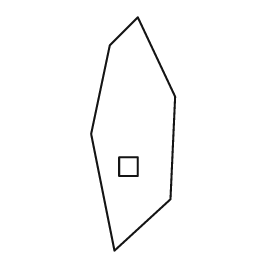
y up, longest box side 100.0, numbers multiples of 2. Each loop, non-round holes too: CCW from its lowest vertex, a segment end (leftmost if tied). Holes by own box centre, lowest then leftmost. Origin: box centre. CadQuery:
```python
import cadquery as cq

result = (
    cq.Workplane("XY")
    .moveTo(-8.0, -50.0)
    .lineTo(16.0, -28.0)
    .lineTo(18.0, 16.0)
    .lineTo(2.0, 50.0)
    .lineTo(-10.0, 38.0)
    .lineTo(-18.0, 0.0)
    .close()
    .moveTo(-6.0, -18.0)
    .lineTo(2.0, -18.0)
    .lineTo(2.0, -10.0)
    .lineTo(-6.0, -10.0)
    .close()
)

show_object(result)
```